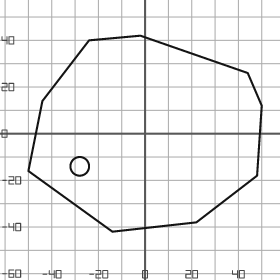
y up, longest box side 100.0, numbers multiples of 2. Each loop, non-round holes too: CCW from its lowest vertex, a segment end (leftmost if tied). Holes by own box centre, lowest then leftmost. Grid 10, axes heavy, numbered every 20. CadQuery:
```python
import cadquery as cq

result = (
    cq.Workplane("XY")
    .moveTo(-14.0, -42.0)
    .lineTo(22.0, -38.0)
    .lineTo(48.0, -18.0)
    .lineTo(50.0, 12.0)
    .lineTo(44.0, 26.0)
    .lineTo(-2.0, 42.0)
    .lineTo(-24.0, 40.0)
    .lineTo(-44.0, 14.0)
    .lineTo(-50.0, -16.0)
    .close()
    .moveTo(-28.0, -14.0)
    .circle(4.0)
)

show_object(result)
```